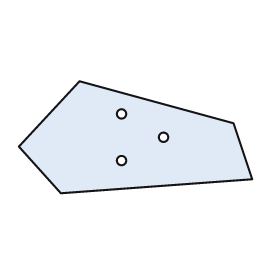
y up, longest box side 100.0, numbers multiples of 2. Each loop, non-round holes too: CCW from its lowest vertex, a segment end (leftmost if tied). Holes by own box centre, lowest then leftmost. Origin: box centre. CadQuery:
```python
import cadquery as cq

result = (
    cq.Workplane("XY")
    .moveTo(-32.0, -24.0)
    .lineTo(50.0, -18.0)
    .lineTo(42.0, 6.0)
    .lineTo(-24.0, 24.0)
    .lineTo(-50.0, -4.0)
    .close()
    .moveTo(-6.0, -10.0)
    .circle(2.0)
    .moveTo(12.0, 0.0)
    .circle(2.0)
    .moveTo(-6.0, 10.0)
    .circle(2.0)
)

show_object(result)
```